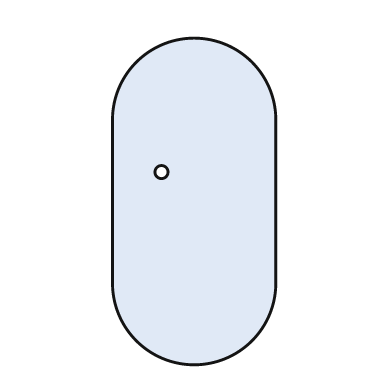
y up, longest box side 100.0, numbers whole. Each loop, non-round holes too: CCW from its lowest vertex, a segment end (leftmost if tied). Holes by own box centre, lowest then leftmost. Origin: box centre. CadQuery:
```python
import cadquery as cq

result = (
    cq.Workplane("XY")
    .moveTo(-25.0, -25.0)
    .threePointArc((0.0, -50.0), (25.0, -25.0))
    .lineTo(25.0, 25.0)
    .threePointArc((0.0, 50.0), (-25.0, 25.0))
    .close()
    .moveTo(-10.0, 9.0)
    .circle(2.0)
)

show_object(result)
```